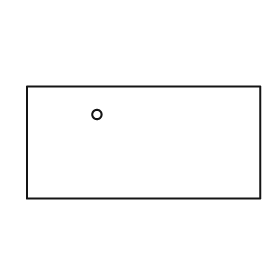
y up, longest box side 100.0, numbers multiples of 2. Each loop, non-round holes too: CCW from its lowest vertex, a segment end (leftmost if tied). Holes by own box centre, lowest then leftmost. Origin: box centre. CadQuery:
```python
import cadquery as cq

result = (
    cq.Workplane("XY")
    .moveTo(-50.0, -24.0)
    .lineTo(50.0, -24.0)
    .lineTo(50.0, 24.0)
    .lineTo(-50.0, 24.0)
    .close()
    .moveTo(-20.0, 12.0)
    .circle(2.0)
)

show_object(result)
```